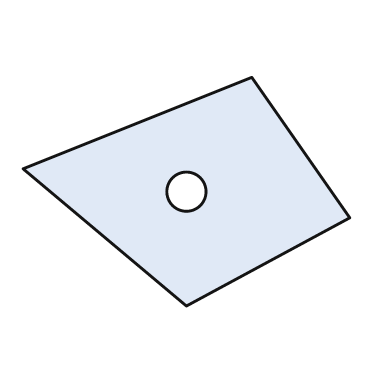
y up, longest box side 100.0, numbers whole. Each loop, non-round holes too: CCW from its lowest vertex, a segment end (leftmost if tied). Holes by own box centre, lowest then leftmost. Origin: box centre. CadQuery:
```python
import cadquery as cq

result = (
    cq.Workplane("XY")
    .moveTo(0.0, -35.0)
    .lineTo(50.0, -8.0)
    .lineTo(20.0, 35.0)
    .lineTo(-50.0, 7.0)
    .close()
    .moveTo(0.0, 0.0)
    .circle(6.0)
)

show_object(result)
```